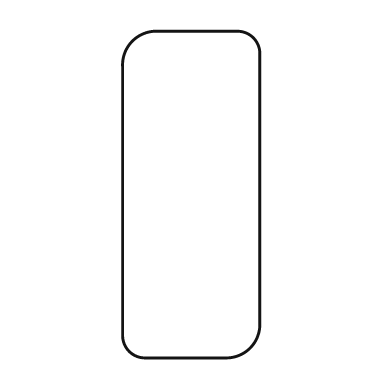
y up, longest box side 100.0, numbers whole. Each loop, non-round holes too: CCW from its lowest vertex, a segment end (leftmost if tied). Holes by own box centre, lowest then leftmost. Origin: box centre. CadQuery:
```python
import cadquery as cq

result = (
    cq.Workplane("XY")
    .moveTo(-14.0, -50.0)
    .lineTo(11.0, -50.0)
    .threePointArc((18.0, -47.0), (21.0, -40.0))
    .lineTo(21.0, 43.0)
    .threePointArc((19.0, 48.0), (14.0, 50.0))
    .lineTo(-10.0, 50.0)
    .threePointArc((-18.0, 47.0), (-21.0, 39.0))
    .lineTo(-21.0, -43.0)
    .threePointArc((-19.0, -48.0), (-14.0, -50.0))
    .close()
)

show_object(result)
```